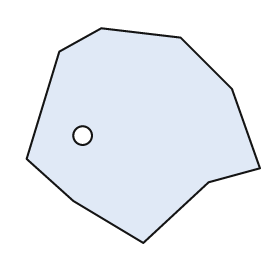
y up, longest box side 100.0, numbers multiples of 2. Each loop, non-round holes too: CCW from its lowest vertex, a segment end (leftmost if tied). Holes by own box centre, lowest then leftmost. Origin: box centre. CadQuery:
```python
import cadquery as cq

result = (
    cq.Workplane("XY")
    .moveTo(0.0, -46.0)
    .lineTo(28.0, -20.0)
    .lineTo(50.0, -14.0)
    .lineTo(38.0, 20.0)
    .lineTo(16.0, 42.0)
    .lineTo(-18.0, 46.0)
    .lineTo(-36.0, 36.0)
    .lineTo(-50.0, -10.0)
    .lineTo(-30.0, -28.0)
    .close()
    .moveTo(-26.0, 0.0)
    .circle(4.0)
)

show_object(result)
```